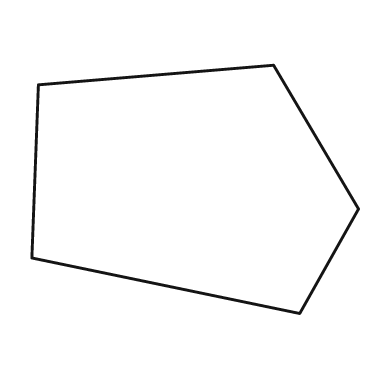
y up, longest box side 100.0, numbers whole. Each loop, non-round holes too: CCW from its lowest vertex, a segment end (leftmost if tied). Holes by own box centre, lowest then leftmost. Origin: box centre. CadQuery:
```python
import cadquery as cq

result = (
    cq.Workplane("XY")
    .moveTo(32.0, -38.0)
    .lineTo(50.0, -6.0)
    .lineTo(24.0, 38.0)
    .lineTo(-48.0, 32.0)
    .lineTo(-50.0, -21.0)
    .close()
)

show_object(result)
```